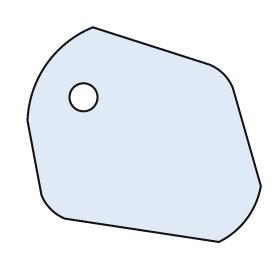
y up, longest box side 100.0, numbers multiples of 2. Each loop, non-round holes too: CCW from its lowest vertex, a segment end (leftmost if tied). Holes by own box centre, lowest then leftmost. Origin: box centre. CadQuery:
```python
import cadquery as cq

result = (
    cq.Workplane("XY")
    .moveTo(32.0, -46.0)
    .threePointArc((44.0, -36.0), (50.0, -22.0))
    .lineTo(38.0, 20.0)
    .threePointArc((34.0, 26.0), (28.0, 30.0))
    .lineTo(-22.0, 46.0)
    .threePointArc((-42.0, 30.0), (-50.0, 6.0))
    .lineTo(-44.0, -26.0)
    .threePointArc((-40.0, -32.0), (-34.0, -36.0))
    .close()
    .moveTo(-26.0, 16.0)
    .circle(6.0)
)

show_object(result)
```